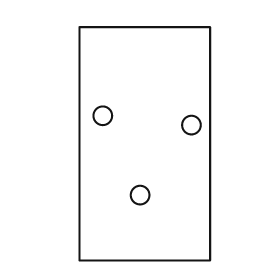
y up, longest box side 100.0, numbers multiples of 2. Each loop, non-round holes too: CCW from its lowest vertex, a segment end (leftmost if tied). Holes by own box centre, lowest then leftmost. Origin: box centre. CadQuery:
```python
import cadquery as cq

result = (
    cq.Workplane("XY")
    .moveTo(-28.0, -50.0)
    .lineTo(28.0, -50.0)
    .lineTo(28.0, 50.0)
    .lineTo(-28.0, 50.0)
    .close()
    .moveTo(-2.0, -22.0)
    .circle(4.0)
    .moveTo(20.0, 8.0)
    .circle(4.0)
    .moveTo(-18.0, 12.0)
    .circle(4.0)
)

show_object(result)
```